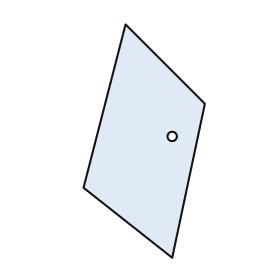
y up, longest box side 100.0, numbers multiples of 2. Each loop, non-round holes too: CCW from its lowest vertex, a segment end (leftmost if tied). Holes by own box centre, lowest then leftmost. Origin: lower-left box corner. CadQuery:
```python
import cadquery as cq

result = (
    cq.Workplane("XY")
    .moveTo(38.0, 0.0)
    .lineTo(52.0, 66.0)
    .lineTo(18.0, 100.0)
    .lineTo(0.0, 30.0)
    .close()
    .moveTo(38.0, 52.0)
    .circle(2.0)
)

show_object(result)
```